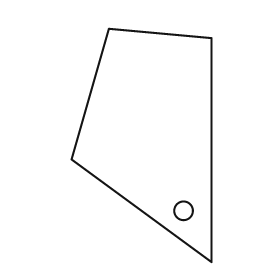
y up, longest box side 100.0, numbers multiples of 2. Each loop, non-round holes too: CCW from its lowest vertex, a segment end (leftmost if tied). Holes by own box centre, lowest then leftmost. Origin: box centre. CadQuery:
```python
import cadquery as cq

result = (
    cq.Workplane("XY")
    .moveTo(30.0, -50.0)
    .lineTo(30.0, 46.0)
    .lineTo(-14.0, 50.0)
    .lineTo(-30.0, -6.0)
    .close()
    .moveTo(18.0, -28.0)
    .circle(4.0)
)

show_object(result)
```